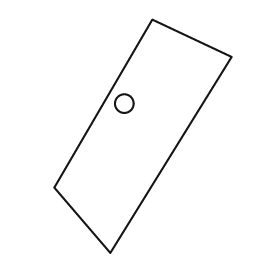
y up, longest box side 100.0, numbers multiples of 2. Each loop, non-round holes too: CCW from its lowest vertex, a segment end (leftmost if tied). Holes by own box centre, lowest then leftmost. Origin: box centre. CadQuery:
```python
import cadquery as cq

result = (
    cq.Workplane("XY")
    .moveTo(-14.0, -50.0)
    .lineTo(38.0, 34.0)
    .lineTo(4.0, 50.0)
    .lineTo(-38.0, -22.0)
    .close()
    .moveTo(-8.0, 14.0)
    .circle(4.0)
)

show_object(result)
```